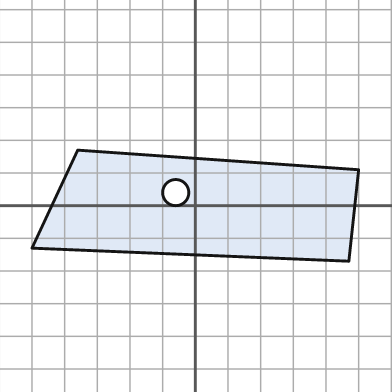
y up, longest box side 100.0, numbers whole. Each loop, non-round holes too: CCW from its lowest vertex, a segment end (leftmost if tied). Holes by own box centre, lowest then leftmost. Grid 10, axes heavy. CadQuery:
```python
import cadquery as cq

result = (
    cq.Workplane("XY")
    .moveTo(47.0, -17.0)
    .lineTo(50.0, 11.0)
    .lineTo(-36.0, 17.0)
    .lineTo(-50.0, -13.0)
    .close()
    .moveTo(-6.0, 4.0)
    .circle(4.0)
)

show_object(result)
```